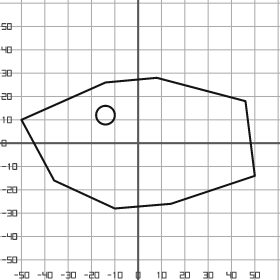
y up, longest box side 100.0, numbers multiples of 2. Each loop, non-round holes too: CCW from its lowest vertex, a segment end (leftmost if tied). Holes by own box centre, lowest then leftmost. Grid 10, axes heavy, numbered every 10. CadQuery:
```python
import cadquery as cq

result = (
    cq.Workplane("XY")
    .moveTo(-10.0, -28.0)
    .lineTo(14.0, -26.0)
    .lineTo(50.0, -14.0)
    .lineTo(46.0, 18.0)
    .lineTo(8.0, 28.0)
    .lineTo(-14.0, 26.0)
    .lineTo(-50.0, 10.0)
    .lineTo(-36.0, -16.0)
    .close()
    .moveTo(-14.0, 12.0)
    .circle(4.0)
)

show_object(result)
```